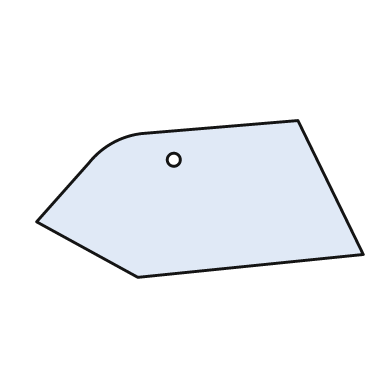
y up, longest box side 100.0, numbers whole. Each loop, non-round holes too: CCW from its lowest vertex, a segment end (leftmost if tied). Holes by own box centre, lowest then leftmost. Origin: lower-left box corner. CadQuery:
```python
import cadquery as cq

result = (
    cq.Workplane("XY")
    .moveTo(31.0, 0.0)
    .lineTo(100.0, 7.0)
    .lineTo(80.0, 48.0)
    .lineTo(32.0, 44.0)
    .threePointArc((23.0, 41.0), (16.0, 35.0))
    .lineTo(0.0, 17.0)
    .close()
    .moveTo(42.0, 36.0)
    .circle(2.0)
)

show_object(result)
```